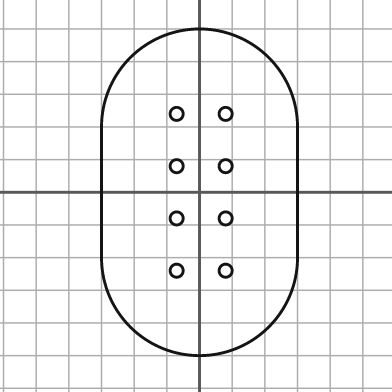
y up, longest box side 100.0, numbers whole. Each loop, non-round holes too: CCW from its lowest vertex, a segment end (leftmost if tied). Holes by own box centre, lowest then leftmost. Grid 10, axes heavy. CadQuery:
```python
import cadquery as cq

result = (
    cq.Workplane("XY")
    .moveTo(-30.0, -20.0)
    .threePointArc((0.0, -50.0), (30.0, -20.0))
    .lineTo(30.0, 20.0)
    .threePointArc((0.0, 50.0), (-30.0, 20.0))
    .close()
    .moveTo(-7.0, -24.0)
    .circle(2.0)
    .moveTo(8.0, -24.0)
    .circle(2.0)
    .moveTo(-7.0, -8.0)
    .circle(2.0)
    .moveTo(8.0, -8.0)
    .circle(2.0)
    .moveTo(-7.0, 8.0)
    .circle(2.0)
    .moveTo(8.0, 8.0)
    .circle(2.0)
    .moveTo(-7.0, 24.0)
    .circle(2.0)
    .moveTo(8.0, 24.0)
    .circle(2.0)
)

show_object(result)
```